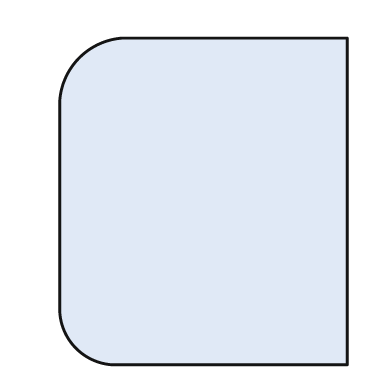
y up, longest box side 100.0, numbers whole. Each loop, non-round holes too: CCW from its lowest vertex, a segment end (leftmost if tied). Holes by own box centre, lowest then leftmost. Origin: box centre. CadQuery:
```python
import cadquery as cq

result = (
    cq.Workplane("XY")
    .moveTo(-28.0, -50.0)
    .lineTo(44.0, -50.0)
    .lineTo(44.0, 50.0)
    .lineTo(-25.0, 50.0)
    .threePointArc((-38.0, 44.0), (-44.0, 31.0))
    .lineTo(-44.0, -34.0)
    .threePointArc((-39.0, -45.0), (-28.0, -50.0))
    .close()
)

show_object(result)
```